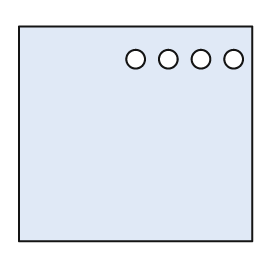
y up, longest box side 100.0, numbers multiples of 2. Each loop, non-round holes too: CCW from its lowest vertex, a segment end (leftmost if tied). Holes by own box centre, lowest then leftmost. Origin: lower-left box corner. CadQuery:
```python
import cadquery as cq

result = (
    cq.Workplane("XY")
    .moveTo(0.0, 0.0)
    .lineTo(100.0, 0.0)
    .lineTo(100.0, 92.0)
    .lineTo(0.0, 92.0)
    .close()
    .moveTo(50.0, 78.0)
    .circle(4.0)
    .moveTo(64.0, 78.0)
    .circle(4.0)
    .moveTo(78.0, 78.0)
    .circle(4.0)
    .moveTo(92.0, 78.0)
    .circle(4.0)
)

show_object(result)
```